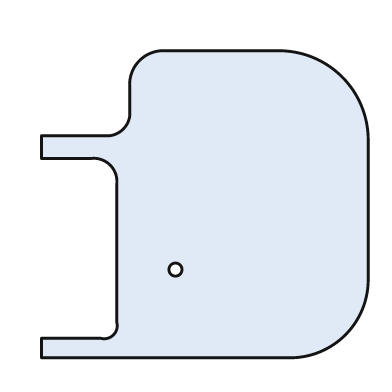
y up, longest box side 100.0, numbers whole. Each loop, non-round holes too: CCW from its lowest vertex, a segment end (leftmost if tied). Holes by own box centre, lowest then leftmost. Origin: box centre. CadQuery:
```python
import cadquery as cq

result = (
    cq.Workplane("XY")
    .moveTo(-50.0, -47.0)
    .lineTo(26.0, -47.0)
    .threePointArc((43.0, -40.0), (50.0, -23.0))
    .lineTo(50.0, 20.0)
    .threePointArc((42.0, 39.0), (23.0, 47.0))
    .lineTo(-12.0, 47.0)
    .threePointArc((-20.0, 44.0), (-23.0, 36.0))
    .lineTo(-23.0, 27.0)
    .threePointArc((-25.0, 23.0), (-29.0, 21.0))
    .lineTo(-50.0, 21.0)
    .lineTo(-50.0, 14.0)
    .lineTo(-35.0, 14.0)
    .threePointArc((-29.0, 12.0), (-27.0, 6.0))
    .lineTo(-27.0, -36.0)
    .threePointArc((-28.0, -40.0), (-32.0, -41.0))
    .lineTo(-50.0, -41.0)
    .close()
    .moveTo(-9.0, -20.0)
    .circle(2.0)
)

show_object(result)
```